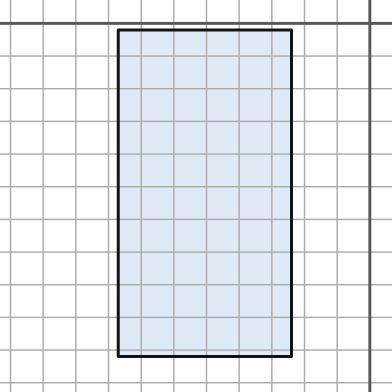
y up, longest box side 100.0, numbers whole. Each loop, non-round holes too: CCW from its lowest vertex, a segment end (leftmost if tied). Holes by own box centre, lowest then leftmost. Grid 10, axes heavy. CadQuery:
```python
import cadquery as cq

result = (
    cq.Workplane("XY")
    .moveTo(-77.0, -102.0)
    .lineTo(-24.0, -102.0)
    .lineTo(-24.0, -2.0)
    .lineTo(-77.0, -2.0)
    .close()
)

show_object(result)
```